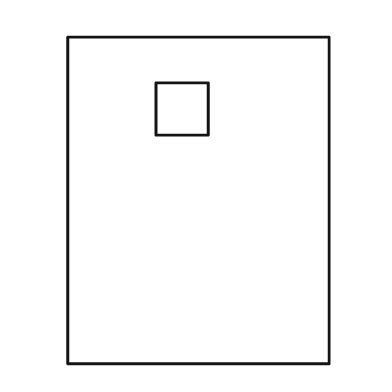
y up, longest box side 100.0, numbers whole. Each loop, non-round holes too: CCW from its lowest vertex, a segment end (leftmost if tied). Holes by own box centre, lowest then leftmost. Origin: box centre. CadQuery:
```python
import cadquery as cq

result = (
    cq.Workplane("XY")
    .moveTo(-40.0, -50.0)
    .lineTo(40.0, -50.0)
    .lineTo(40.0, 50.0)
    .lineTo(-40.0, 50.0)
    .close()
    .moveTo(-13.0, 20.0)
    .lineTo(3.0, 20.0)
    .lineTo(3.0, 36.0)
    .lineTo(-13.0, 36.0)
    .close()
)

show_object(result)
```